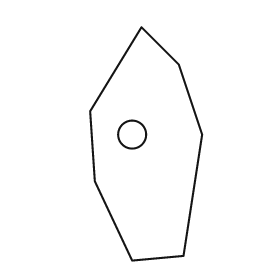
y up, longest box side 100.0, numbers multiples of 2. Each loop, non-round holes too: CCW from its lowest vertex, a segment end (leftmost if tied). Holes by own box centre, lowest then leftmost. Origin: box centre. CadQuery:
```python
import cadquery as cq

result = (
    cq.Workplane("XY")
    .moveTo(-6.0, -50.0)
    .lineTo(16.0, -48.0)
    .lineTo(24.0, 4.0)
    .lineTo(14.0, 34.0)
    .lineTo(-2.0, 50.0)
    .lineTo(-24.0, 14.0)
    .lineTo(-22.0, -16.0)
    .close()
    .moveTo(-6.0, 4.0)
    .circle(6.0)
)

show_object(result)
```